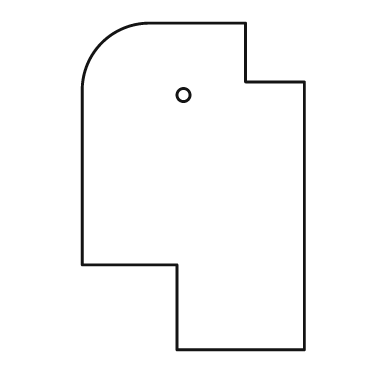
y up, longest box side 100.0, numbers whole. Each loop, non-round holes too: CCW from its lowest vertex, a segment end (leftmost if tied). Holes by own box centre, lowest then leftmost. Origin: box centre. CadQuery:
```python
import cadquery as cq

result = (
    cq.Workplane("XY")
    .moveTo(-5.0, -50.0)
    .lineTo(34.0, -50.0)
    .lineTo(34.0, 32.0)
    .lineTo(16.0, 32.0)
    .lineTo(16.0, 50.0)
    .lineTo(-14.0, 50.0)
    .threePointArc((-28.0, 44.0), (-34.0, 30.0))
    .lineTo(-34.0, -24.0)
    .lineTo(-5.0, -24.0)
    .close()
    .moveTo(-3.0, 28.0)
    .circle(2.0)
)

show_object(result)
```